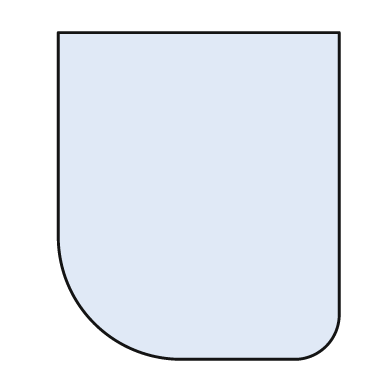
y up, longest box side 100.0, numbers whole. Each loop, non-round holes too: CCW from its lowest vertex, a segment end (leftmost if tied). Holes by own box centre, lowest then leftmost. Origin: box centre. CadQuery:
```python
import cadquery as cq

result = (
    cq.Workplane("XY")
    .moveTo(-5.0, -50.0)
    .lineTo(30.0, -50.0)
    .threePointArc((39.0, -46.0), (43.0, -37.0))
    .lineTo(43.0, 50.0)
    .lineTo(-43.0, 50.0)
    .lineTo(-43.0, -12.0)
    .threePointArc((-32.0, -39.0), (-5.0, -50.0))
    .close()
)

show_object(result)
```